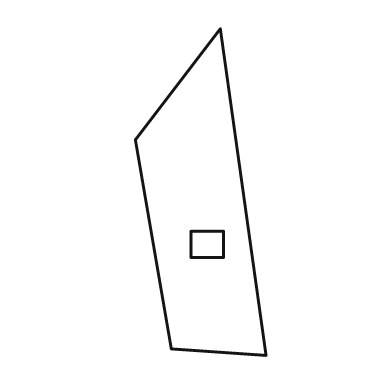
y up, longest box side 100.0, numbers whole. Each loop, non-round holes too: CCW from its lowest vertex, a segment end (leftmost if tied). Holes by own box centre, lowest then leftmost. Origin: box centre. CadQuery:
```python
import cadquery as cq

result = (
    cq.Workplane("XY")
    .moveTo(20.0, -50.0)
    .lineTo(6.0, 50.0)
    .lineTo(-20.0, 16.0)
    .lineTo(-9.0, -48.0)
    .close()
    .moveTo(-3.0, -20.0)
    .lineTo(7.0, -20.0)
    .lineTo(7.0, -12.0)
    .lineTo(-3.0, -12.0)
    .close()
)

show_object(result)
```